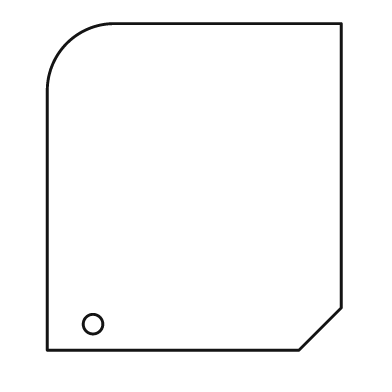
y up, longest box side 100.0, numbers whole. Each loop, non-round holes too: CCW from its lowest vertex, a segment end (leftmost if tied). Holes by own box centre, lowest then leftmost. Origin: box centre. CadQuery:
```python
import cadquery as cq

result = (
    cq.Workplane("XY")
    .moveTo(-45.0, -50.0)
    .lineTo(32.0, -50.0)
    .lineTo(45.0, -37.0)
    .lineTo(45.0, 50.0)
    .lineTo(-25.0, 50.0)
    .threePointArc((-39.0, 44.0), (-45.0, 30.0))
    .close()
    .moveTo(-31.0, -42.0)
    .circle(3.0)
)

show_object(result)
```